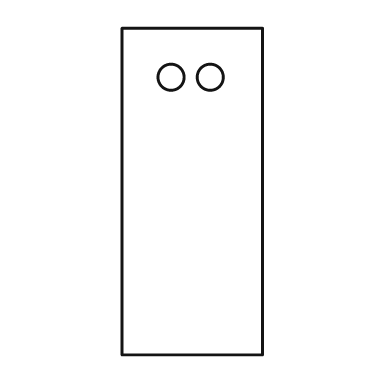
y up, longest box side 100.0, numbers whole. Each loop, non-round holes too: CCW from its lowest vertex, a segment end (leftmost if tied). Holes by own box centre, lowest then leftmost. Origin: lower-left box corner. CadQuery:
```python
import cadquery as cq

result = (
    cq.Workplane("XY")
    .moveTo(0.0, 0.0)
    .lineTo(43.0, 0.0)
    .lineTo(43.0, 100.0)
    .lineTo(0.0, 100.0)
    .close()
    .moveTo(15.0, 85.0)
    .circle(4.0)
    .moveTo(27.0, 85.0)
    .circle(4.0)
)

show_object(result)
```